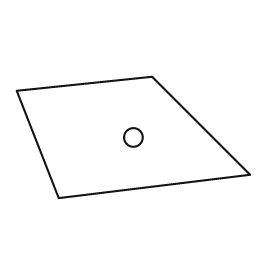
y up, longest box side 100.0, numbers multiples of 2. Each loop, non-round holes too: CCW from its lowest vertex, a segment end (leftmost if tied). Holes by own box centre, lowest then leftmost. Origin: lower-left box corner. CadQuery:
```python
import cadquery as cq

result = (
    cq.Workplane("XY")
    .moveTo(18.0, 0.0)
    .lineTo(100.0, 10.0)
    .lineTo(58.0, 52.0)
    .lineTo(0.0, 46.0)
    .close()
    .moveTo(50.0, 26.0)
    .circle(4.0)
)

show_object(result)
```